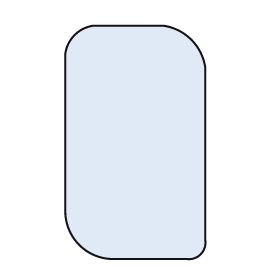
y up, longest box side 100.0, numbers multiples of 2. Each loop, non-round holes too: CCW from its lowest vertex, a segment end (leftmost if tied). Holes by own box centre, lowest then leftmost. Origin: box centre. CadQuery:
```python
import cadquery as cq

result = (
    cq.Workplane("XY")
    .moveTo(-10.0, -50.0)
    .lineTo(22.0, -50.0)
    .threePointArc((28.0, -48.0), (30.0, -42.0))
    .lineTo(30.0, 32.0)
    .threePointArc((24.0, 44.0), (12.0, 50.0))
    .lineTo(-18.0, 50.0)
    .threePointArc((-26.0, 46.0), (-30.0, 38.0))
    .lineTo(-30.0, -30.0)
    .threePointArc((-24.0, -44.0), (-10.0, -50.0))
    .close()
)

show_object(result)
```